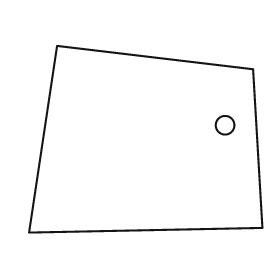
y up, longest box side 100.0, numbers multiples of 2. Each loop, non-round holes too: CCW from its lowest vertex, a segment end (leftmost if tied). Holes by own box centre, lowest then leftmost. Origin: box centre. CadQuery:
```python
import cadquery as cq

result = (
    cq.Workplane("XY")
    .moveTo(-50.0, -40.0)
    .lineTo(50.0, -38.0)
    .lineTo(46.0, 30.0)
    .lineTo(-38.0, 40.0)
    .close()
    .moveTo(34.0, 6.0)
    .circle(4.0)
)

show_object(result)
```